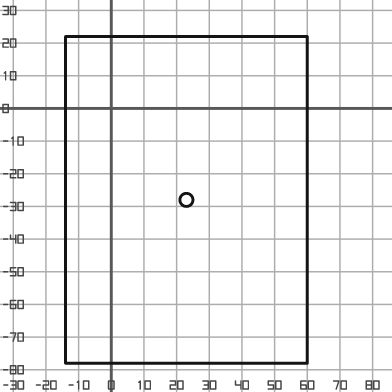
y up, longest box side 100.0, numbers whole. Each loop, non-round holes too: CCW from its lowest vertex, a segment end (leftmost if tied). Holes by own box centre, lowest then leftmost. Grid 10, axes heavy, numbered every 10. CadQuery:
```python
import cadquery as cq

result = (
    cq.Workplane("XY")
    .moveTo(-14.0, -78.0)
    .lineTo(60.0, -78.0)
    .lineTo(60.0, 22.0)
    .lineTo(-14.0, 22.0)
    .close()
    .moveTo(23.0, -28.0)
    .circle(2.0)
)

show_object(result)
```